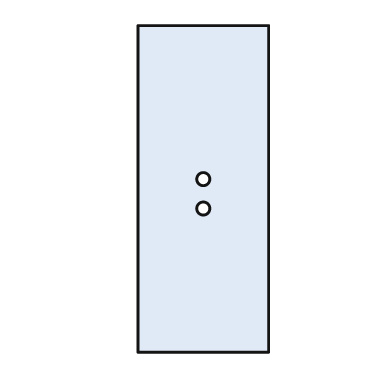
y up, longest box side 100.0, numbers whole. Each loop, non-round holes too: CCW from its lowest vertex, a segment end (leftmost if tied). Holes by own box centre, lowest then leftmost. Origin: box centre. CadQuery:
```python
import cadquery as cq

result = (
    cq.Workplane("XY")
    .moveTo(-20.0, -50.0)
    .lineTo(20.0, -50.0)
    .lineTo(20.0, 50.0)
    .lineTo(-20.0, 50.0)
    .close()
    .moveTo(0.0, -6.0)
    .circle(2.0)
    .moveTo(0.0, 3.0)
    .circle(2.0)
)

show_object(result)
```